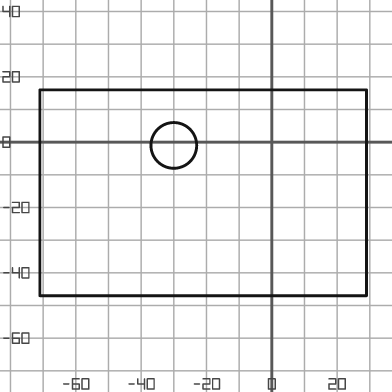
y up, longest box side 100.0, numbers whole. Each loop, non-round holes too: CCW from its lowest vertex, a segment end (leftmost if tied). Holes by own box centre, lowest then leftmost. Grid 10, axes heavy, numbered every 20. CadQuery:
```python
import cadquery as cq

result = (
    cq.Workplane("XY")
    .moveTo(-71.0, -47.0)
    .lineTo(29.0, -47.0)
    .lineTo(29.0, 16.0)
    .lineTo(-71.0, 16.0)
    .close()
    .moveTo(-30.0, -1.0)
    .circle(7.0)
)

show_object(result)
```